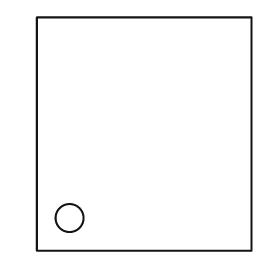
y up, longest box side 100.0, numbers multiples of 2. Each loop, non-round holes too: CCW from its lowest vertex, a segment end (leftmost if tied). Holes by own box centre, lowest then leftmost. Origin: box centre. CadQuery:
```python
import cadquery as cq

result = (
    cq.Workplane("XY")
    .moveTo(-46.0, -50.0)
    .lineTo(46.0, -50.0)
    .lineTo(46.0, 50.0)
    .lineTo(-46.0, 50.0)
    .close()
    .moveTo(-32.0, -36.0)
    .circle(6.0)
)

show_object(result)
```